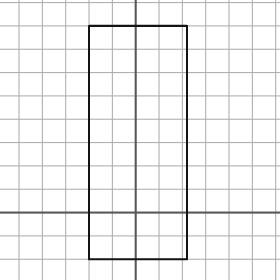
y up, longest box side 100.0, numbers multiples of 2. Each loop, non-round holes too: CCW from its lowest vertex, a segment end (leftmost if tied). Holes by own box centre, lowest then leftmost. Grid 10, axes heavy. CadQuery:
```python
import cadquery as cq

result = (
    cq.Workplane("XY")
    .moveTo(-20.0, -20.0)
    .lineTo(22.0, -20.0)
    .lineTo(22.0, 80.0)
    .lineTo(-20.0, 80.0)
    .close()
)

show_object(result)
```